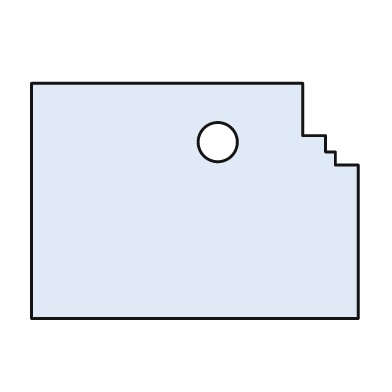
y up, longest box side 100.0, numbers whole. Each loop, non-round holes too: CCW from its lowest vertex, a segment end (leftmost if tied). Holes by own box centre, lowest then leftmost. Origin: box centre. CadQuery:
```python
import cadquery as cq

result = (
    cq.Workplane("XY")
    .moveTo(-50.0, -36.0)
    .lineTo(50.0, -36.0)
    .lineTo(50.0, 11.0)
    .lineTo(43.0, 11.0)
    .lineTo(43.0, 15.0)
    .lineTo(40.0, 15.0)
    .lineTo(40.0, 20.0)
    .lineTo(33.0, 20.0)
    .lineTo(33.0, 36.0)
    .lineTo(-50.0, 36.0)
    .close()
    .moveTo(7.0, 18.0)
    .circle(6.0)
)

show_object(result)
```